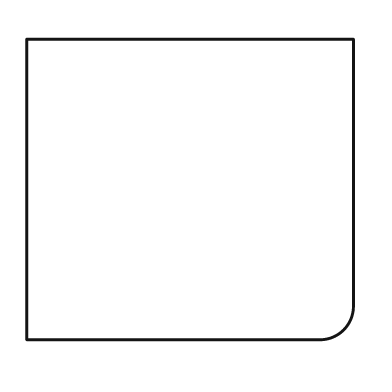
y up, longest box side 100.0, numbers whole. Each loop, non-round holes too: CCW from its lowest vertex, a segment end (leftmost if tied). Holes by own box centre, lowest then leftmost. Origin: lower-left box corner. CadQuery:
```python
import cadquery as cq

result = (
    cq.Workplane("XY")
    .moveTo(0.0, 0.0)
    .lineTo(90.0, 0.0)
    .threePointArc((97.0, 3.0), (100.0, 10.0))
    .lineTo(100.0, 92.0)
    .lineTo(0.0, 92.0)
    .close()
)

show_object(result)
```